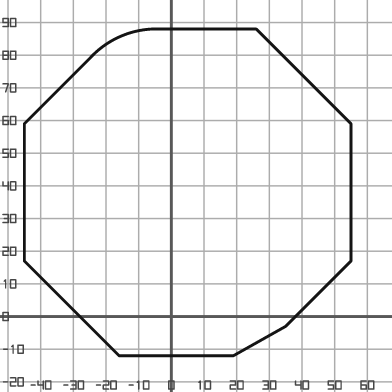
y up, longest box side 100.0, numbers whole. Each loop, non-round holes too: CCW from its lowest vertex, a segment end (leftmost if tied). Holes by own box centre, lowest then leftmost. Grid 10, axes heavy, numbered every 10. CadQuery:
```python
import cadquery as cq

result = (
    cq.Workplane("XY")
    .moveTo(-16.0, -12.0)
    .lineTo(19.0, -12.0)
    .lineTo(35.0, -3.0)
    .lineTo(55.0, 17.0)
    .lineTo(55.0, 59.0)
    .lineTo(26.0, 88.0)
    .lineTo(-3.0, 88.0)
    .threePointArc((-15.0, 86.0), (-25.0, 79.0))
    .lineTo(-45.0, 59.0)
    .lineTo(-45.0, 17.0)
    .close()
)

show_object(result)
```